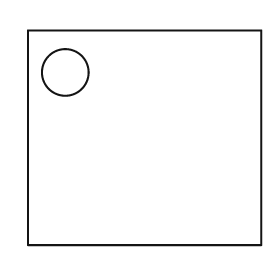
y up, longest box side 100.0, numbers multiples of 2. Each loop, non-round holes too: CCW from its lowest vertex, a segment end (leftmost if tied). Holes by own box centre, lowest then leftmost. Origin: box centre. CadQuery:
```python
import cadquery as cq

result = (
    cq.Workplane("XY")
    .moveTo(-50.0, -46.0)
    .lineTo(50.0, -46.0)
    .lineTo(50.0, 46.0)
    .lineTo(-50.0, 46.0)
    .close()
    .moveTo(-34.0, 28.0)
    .circle(10.0)
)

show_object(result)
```